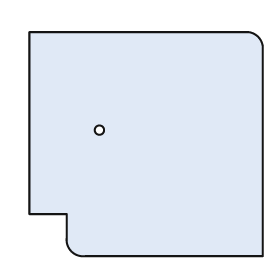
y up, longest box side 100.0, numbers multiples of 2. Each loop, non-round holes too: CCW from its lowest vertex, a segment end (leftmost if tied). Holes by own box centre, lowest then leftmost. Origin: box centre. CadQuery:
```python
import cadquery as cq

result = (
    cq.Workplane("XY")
    .moveTo(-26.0, -48.0)
    .lineTo(50.0, -48.0)
    .lineTo(50.0, 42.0)
    .threePointArc((48.0, 46.0), (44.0, 48.0))
    .lineTo(-50.0, 48.0)
    .lineTo(-50.0, -30.0)
    .lineTo(-34.0, -30.0)
    .lineTo(-34.0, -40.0)
    .threePointArc((-32.0, -46.0), (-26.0, -48.0))
    .close()
    .moveTo(-20.0, 6.0)
    .circle(2.0)
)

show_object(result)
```